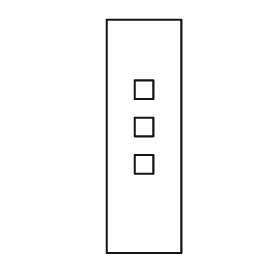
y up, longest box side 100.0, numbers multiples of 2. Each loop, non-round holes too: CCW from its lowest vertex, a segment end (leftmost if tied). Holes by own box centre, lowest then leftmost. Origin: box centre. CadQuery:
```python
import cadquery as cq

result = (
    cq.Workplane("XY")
    .moveTo(-16.0, -50.0)
    .lineTo(16.0, -50.0)
    .lineTo(16.0, 50.0)
    .lineTo(-16.0, 50.0)
    .close()
    .moveTo(-4.0, -16.0)
    .lineTo(4.0, -16.0)
    .lineTo(4.0, -8.0)
    .lineTo(-4.0, -8.0)
    .close()
    .moveTo(-4.0, 0.0)
    .lineTo(4.0, 0.0)
    .lineTo(4.0, 8.0)
    .lineTo(-4.0, 8.0)
    .close()
    .moveTo(-4.0, 16.0)
    .lineTo(4.0, 16.0)
    .lineTo(4.0, 24.0)
    .lineTo(-4.0, 24.0)
    .close()
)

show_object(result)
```